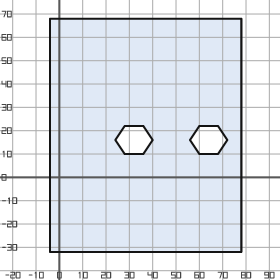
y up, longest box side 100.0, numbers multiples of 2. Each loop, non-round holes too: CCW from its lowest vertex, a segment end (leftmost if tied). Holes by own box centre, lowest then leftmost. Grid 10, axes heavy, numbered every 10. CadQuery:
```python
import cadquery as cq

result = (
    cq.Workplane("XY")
    .moveTo(-4.0, -32.0)
    .lineTo(78.0, -32.0)
    .lineTo(78.0, 68.0)
    .lineTo(-4.0, 68.0)
    .close()
    .moveTo(28.0, 10.0)
    .lineTo(36.0, 10.0)
    .lineTo(40.0, 16.0)
    .lineTo(36.0, 22.0)
    .lineTo(28.0, 22.0)
    .lineTo(24.0, 16.0)
    .close()
    .moveTo(60.0, 10.0)
    .lineTo(68.0, 10.0)
    .lineTo(72.0, 16.0)
    .lineTo(68.0, 22.0)
    .lineTo(60.0, 22.0)
    .lineTo(56.0, 16.0)
    .close()
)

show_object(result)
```